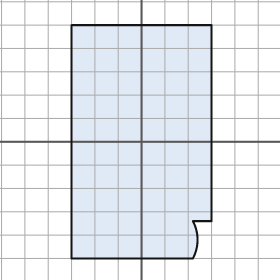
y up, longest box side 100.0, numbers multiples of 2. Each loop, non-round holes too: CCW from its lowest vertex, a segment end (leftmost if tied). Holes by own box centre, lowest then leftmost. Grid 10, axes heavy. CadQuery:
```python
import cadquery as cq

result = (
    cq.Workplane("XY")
    .moveTo(-30.0, -50.0)
    .lineTo(22.0, -50.0)
    .threePointArc((24.0, -42.0), (22.0, -34.0))
    .lineTo(30.0, -34.0)
    .lineTo(30.0, 50.0)
    .lineTo(-30.0, 50.0)
    .close()
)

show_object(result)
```